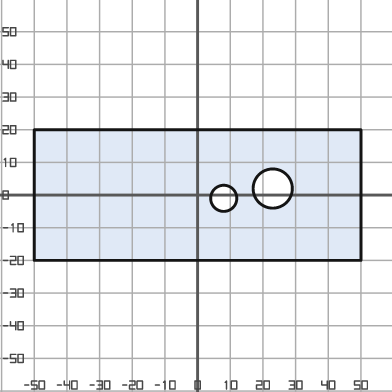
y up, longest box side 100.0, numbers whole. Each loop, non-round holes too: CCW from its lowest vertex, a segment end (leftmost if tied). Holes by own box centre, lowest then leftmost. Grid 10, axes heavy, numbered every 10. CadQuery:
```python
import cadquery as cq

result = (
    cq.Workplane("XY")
    .moveTo(-50.0, -20.0)
    .lineTo(50.0, -20.0)
    .lineTo(50.0, 20.0)
    .lineTo(-50.0, 20.0)
    .close()
    .moveTo(8.0, -1.0)
    .circle(4.0)
    .moveTo(23.0, 2.0)
    .circle(6.0)
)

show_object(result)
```